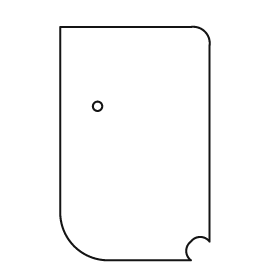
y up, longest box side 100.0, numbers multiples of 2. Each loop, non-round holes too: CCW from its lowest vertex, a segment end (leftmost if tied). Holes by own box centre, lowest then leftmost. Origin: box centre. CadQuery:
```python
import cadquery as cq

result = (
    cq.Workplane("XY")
    .moveTo(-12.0, -50.0)
    .lineTo(24.0, -50.0)
    .threePointArc((22.0, -46.0), (24.0, -42.0))
    .threePointArc((28.0, -40.0), (32.0, -42.0))
    .lineTo(32.0, 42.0)
    .threePointArc((30.0, 48.0), (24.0, 50.0))
    .lineTo(-32.0, 50.0)
    .lineTo(-32.0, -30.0)
    .threePointArc((-26.0, -44.0), (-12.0, -50.0))
    .close()
    .moveTo(-16.0, 16.0)
    .circle(2.0)
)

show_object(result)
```